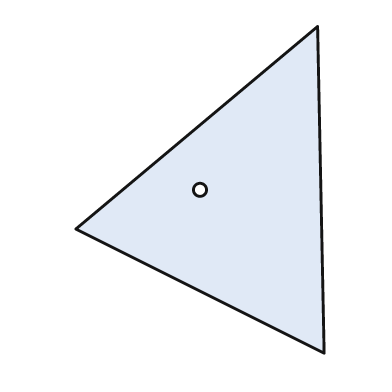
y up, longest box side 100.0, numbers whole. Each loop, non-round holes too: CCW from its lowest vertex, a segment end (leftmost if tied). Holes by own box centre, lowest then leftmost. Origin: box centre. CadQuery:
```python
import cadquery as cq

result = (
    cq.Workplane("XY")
    .moveTo(38.0, -50.0)
    .lineTo(36.0, 50.0)
    .lineTo(-38.0, -12.0)
    .close()
    .moveTo(0.0, 0.0)
    .circle(2.0)
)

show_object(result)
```